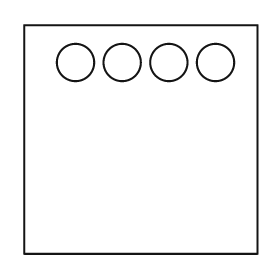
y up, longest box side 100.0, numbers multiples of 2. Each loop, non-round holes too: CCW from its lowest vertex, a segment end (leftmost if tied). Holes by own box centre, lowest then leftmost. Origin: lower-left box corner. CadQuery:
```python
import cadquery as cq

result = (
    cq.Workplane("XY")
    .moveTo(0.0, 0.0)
    .lineTo(100.0, 0.0)
    .lineTo(100.0, 98.0)
    .lineTo(0.0, 98.0)
    .close()
    .moveTo(22.0, 82.0)
    .circle(8.0)
    .moveTo(42.0, 82.0)
    .circle(8.0)
    .moveTo(62.0, 82.0)
    .circle(8.0)
    .moveTo(82.0, 82.0)
    .circle(8.0)
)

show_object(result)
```